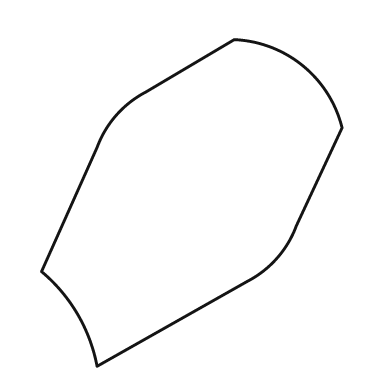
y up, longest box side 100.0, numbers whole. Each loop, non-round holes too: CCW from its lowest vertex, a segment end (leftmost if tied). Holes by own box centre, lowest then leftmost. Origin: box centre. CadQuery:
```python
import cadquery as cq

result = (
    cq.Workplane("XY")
    .moveTo(-29.0, -50.0)
    .lineTo(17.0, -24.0)
    .threePointArc((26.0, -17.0), (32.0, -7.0))
    .lineTo(46.0, 23.0)
    .threePointArc((34.0, 42.0), (13.0, 50.0))
    .lineTo(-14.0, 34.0)
    .threePointArc((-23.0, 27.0), (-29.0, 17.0))
    .lineTo(-46.0, -21.0)
    .threePointArc((-35.0, -34.0), (-29.0, -50.0))
    .close()
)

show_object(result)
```